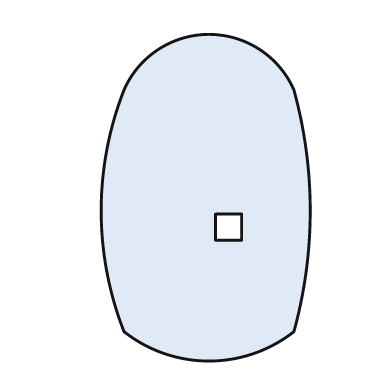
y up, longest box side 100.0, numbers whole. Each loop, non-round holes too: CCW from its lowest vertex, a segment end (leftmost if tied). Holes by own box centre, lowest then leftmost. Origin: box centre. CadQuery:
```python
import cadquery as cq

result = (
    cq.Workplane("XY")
    .moveTo(-25.0, -41.0)
    .threePointArc((1.0, -50.0), (27.0, -41.0))
    .threePointArc((32.0, -4.0), (27.0, 33.0))
    .threePointArc((1.0, 50.0), (-25.0, 33.0))
    .threePointArc((-32.0, -4.0), (-25.0, -41.0))
    .close()
    .moveTo(3.0, -13.0)
    .lineTo(11.0, -13.0)
    .lineTo(11.0, -5.0)
    .lineTo(3.0, -5.0)
    .close()
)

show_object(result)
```